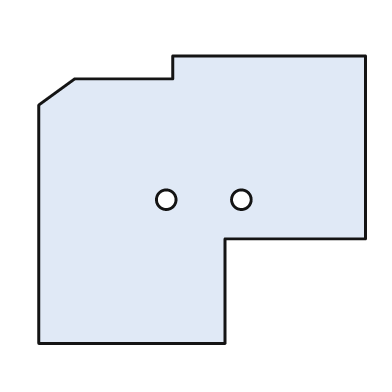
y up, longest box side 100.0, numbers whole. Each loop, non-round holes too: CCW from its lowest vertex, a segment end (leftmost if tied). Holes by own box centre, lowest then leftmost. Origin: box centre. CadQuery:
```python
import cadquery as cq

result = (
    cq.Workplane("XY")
    .moveTo(-50.0, -44.0)
    .lineTo(7.0, -44.0)
    .lineTo(7.0, -12.0)
    .lineTo(50.0, -12.0)
    .lineTo(50.0, 44.0)
    .lineTo(-9.0, 44.0)
    .lineTo(-9.0, 37.0)
    .lineTo(-39.0, 37.0)
    .lineTo(-50.0, 29.0)
    .close()
    .moveTo(-11.0, 0.0)
    .circle(3.0)
    .moveTo(12.0, 0.0)
    .circle(3.0)
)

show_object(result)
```